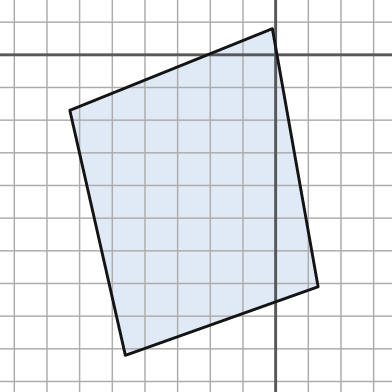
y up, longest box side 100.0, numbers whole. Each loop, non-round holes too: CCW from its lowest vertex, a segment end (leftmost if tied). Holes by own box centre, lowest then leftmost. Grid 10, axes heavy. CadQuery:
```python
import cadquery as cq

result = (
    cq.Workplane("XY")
    .moveTo(-46.0, -92.0)
    .lineTo(13.0, -71.0)
    .lineTo(-1.0, 8.0)
    .lineTo(-63.0, -17.0)
    .close()
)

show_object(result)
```